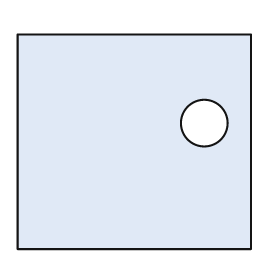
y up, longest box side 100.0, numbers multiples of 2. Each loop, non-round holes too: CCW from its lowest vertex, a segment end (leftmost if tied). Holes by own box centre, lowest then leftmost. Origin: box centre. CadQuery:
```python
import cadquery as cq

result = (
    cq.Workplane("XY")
    .moveTo(-50.0, -46.0)
    .lineTo(50.0, -46.0)
    .lineTo(50.0, 46.0)
    .lineTo(-50.0, 46.0)
    .close()
    .moveTo(30.0, 8.0)
    .circle(10.0)
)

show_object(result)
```